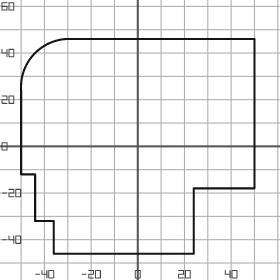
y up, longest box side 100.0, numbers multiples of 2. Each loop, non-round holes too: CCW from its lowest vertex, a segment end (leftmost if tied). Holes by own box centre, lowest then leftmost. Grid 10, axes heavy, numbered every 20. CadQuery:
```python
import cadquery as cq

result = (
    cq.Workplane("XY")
    .moveTo(-36.0, -46.0)
    .lineTo(24.0, -46.0)
    .lineTo(24.0, -18.0)
    .lineTo(50.0, -18.0)
    .lineTo(50.0, 46.0)
    .lineTo(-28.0, 46.0)
    .threePointArc((-44.0, 40.0), (-50.0, 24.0))
    .lineTo(-50.0, -12.0)
    .lineTo(-44.0, -12.0)
    .lineTo(-44.0, -32.0)
    .lineTo(-36.0, -32.0)
    .close()
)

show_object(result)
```